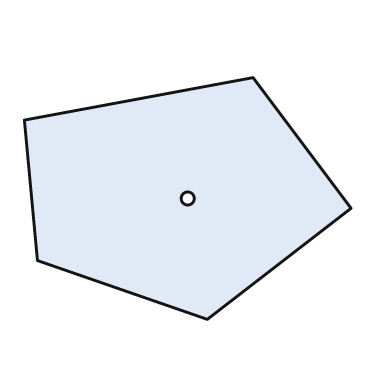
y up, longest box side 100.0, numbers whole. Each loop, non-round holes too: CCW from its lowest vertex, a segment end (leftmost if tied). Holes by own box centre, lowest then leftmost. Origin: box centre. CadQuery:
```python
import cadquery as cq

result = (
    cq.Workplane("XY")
    .moveTo(6.0, -37.0)
    .lineTo(50.0, -3.0)
    .lineTo(20.0, 37.0)
    .lineTo(-50.0, 24.0)
    .lineTo(-46.0, -19.0)
    .close()
    .moveTo(0.0, 0.0)
    .circle(2.0)
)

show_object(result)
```